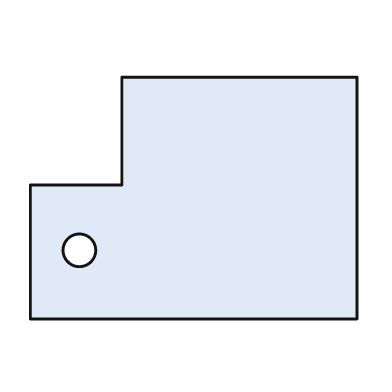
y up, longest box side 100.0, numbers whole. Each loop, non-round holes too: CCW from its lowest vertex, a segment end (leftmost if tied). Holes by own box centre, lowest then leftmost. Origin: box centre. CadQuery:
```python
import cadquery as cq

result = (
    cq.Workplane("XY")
    .moveTo(-50.0, -37.0)
    .lineTo(50.0, -37.0)
    .lineTo(50.0, 37.0)
    .lineTo(-22.0, 37.0)
    .lineTo(-22.0, 4.0)
    .lineTo(-50.0, 4.0)
    .close()
    .moveTo(-35.0, -16.0)
    .circle(5.0)
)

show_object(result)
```